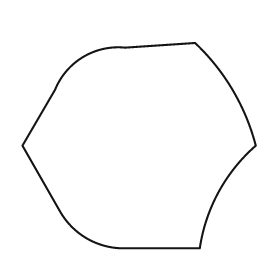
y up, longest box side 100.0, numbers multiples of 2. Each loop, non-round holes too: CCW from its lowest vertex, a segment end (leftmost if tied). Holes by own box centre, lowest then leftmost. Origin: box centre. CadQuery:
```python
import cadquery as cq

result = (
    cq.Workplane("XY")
    .moveTo(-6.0, -44.0)
    .lineTo(26.0, -44.0)
    .threePointArc((34.0, -20.0), (50.0, 0.0))
    .threePointArc((40.0, 24.0), (24.0, 44.0))
    .lineTo(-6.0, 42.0)
    .threePointArc((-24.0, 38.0), (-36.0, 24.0))
    .lineTo(-50.0, 0.0)
    .lineTo(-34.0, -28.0)
    .threePointArc((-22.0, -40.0), (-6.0, -44.0))
    .close()
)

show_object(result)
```